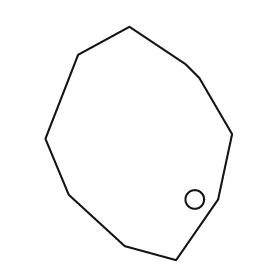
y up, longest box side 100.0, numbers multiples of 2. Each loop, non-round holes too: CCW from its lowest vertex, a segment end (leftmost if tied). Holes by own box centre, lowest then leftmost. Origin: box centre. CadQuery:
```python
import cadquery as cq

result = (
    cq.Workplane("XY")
    .moveTo(16.0, -50.0)
    .lineTo(34.0, -24.0)
    .lineTo(40.0, 4.0)
    .lineTo(26.0, 28.0)
    .lineTo(20.0, 34.0)
    .lineTo(-4.0, 50.0)
    .lineTo(-26.0, 38.0)
    .lineTo(-40.0, 2.0)
    .lineTo(-30.0, -22.0)
    .lineTo(-6.0, -44.0)
    .close()
    .moveTo(24.0, -24.0)
    .circle(4.0)
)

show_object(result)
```